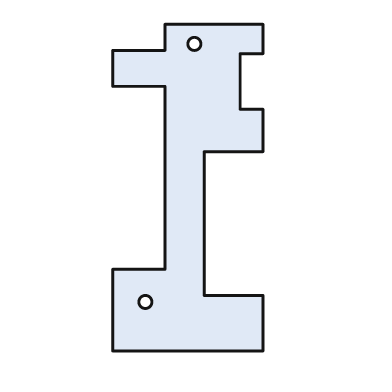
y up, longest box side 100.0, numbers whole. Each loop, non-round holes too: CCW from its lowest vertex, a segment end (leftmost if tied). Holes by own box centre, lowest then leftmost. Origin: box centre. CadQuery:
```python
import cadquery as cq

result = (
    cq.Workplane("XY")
    .moveTo(-23.0, -50.0)
    .lineTo(23.0, -50.0)
    .lineTo(23.0, -33.0)
    .lineTo(5.0, -33.0)
    .lineTo(5.0, 11.0)
    .lineTo(23.0, 11.0)
    .lineTo(23.0, 24.0)
    .lineTo(16.0, 24.0)
    .lineTo(16.0, 41.0)
    .lineTo(23.0, 41.0)
    .lineTo(23.0, 50.0)
    .lineTo(-7.0, 50.0)
    .lineTo(-7.0, 42.0)
    .lineTo(-23.0, 42.0)
    .lineTo(-23.0, 31.0)
    .lineTo(-7.0, 31.0)
    .lineTo(-7.0, -25.0)
    .lineTo(-23.0, -25.0)
    .close()
    .moveTo(-13.0, -35.0)
    .circle(2.0)
    .moveTo(2.0, 44.0)
    .circle(2.0)
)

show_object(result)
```